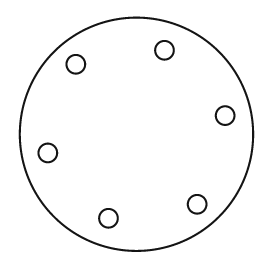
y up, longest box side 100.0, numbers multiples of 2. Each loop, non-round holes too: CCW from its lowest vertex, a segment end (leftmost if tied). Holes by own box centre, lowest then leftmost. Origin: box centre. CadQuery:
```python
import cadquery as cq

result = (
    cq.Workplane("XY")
    .moveTo(0.0, 0.0)
    .circle(50.0)
    .moveTo(-12.0, -36.0)
    .circle(4.0)
    .moveTo(26.0, -30.0)
    .circle(4.0)
    .moveTo(-38.0, -8.0)
    .circle(4.0)
    .moveTo(38.0, 8.0)
    .circle(4.0)
    .moveTo(-26.0, 30.0)
    .circle(4.0)
    .moveTo(12.0, 36.0)
    .circle(4.0)
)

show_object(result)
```